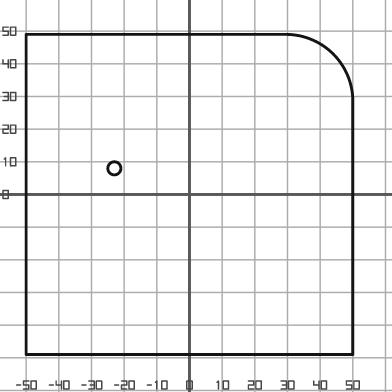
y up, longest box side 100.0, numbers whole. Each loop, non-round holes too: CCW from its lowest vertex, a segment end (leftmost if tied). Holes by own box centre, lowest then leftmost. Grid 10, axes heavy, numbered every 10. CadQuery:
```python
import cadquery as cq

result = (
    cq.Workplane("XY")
    .moveTo(-50.0, -49.0)
    .lineTo(50.0, -49.0)
    .lineTo(50.0, 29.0)
    .threePointArc((44.0, 43.0), (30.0, 49.0))
    .lineTo(-50.0, 49.0)
    .close()
    .moveTo(-23.0, 8.0)
    .circle(2.0)
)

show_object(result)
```